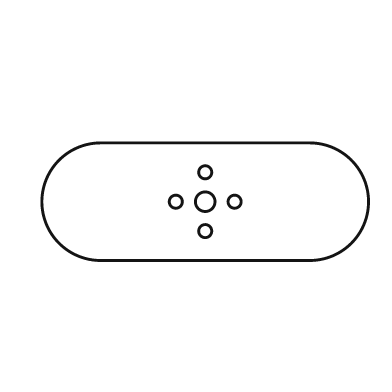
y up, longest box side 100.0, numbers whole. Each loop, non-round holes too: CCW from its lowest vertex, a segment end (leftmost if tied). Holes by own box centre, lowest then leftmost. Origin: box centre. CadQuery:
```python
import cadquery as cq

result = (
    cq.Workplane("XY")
    .moveTo(-32.0, -18.0)
    .lineTo(32.0, -18.0)
    .threePointArc((50.0, 0.0), (32.0, 18.0))
    .lineTo(-32.0, 18.0)
    .threePointArc((-50.0, 0.0), (-32.0, -18.0))
    .close()
    .moveTo(0.0, -9.0)
    .circle(2.0)
    .moveTo(-9.0, 0.0)
    .circle(2.0)
    .moveTo(0.0, 0.0)
    .circle(3.0)
    .moveTo(9.0, 0.0)
    .circle(2.0)
    .moveTo(0.0, 9.0)
    .circle(2.0)
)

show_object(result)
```